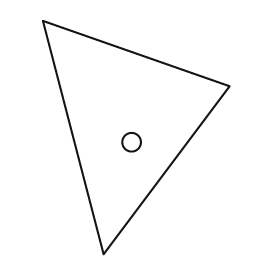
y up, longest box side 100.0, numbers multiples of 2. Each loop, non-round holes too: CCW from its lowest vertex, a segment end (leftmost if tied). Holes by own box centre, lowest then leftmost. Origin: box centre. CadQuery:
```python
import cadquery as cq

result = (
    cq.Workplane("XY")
    .moveTo(-14.0, -50.0)
    .lineTo(40.0, 22.0)
    .lineTo(-40.0, 50.0)
    .close()
    .moveTo(-2.0, -2.0)
    .circle(4.0)
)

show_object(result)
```